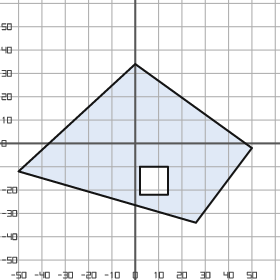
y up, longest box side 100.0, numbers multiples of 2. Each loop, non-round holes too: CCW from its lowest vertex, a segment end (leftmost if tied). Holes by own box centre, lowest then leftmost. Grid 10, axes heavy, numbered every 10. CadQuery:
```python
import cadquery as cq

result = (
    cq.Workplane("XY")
    .moveTo(26.0, -34.0)
    .lineTo(50.0, -2.0)
    .lineTo(0.0, 34.0)
    .lineTo(-50.0, -12.0)
    .close()
    .moveTo(2.0, -22.0)
    .lineTo(14.0, -22.0)
    .lineTo(14.0, -10.0)
    .lineTo(2.0, -10.0)
    .close()
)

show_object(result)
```